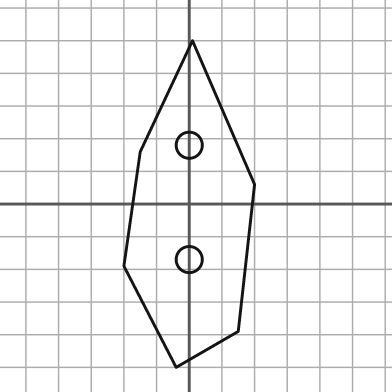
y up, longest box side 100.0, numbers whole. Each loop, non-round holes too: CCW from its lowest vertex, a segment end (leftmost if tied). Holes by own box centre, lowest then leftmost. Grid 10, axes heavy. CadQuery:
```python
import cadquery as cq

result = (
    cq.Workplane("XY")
    .moveTo(-4.0, -50.0)
    .lineTo(15.0, -39.0)
    .lineTo(20.0, 6.0)
    .lineTo(1.0, 50.0)
    .lineTo(-15.0, 16.0)
    .lineTo(-20.0, -19.0)
    .close()
    .moveTo(0.0, -17.0)
    .circle(4.0)
    .moveTo(0.0, 18.0)
    .circle(4.0)
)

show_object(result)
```